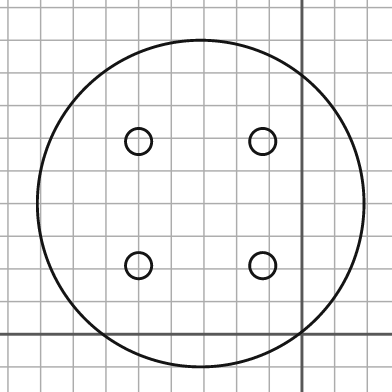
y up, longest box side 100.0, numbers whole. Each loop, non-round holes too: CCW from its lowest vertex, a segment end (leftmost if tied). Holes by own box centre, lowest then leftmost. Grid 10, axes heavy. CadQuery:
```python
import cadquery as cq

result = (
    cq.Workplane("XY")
    .moveTo(-31.0, 40.0)
    .circle(50.0)
    .moveTo(-50.0, 21.0)
    .circle(4.0)
    .moveTo(-12.0, 21.0)
    .circle(4.0)
    .moveTo(-50.0, 59.0)
    .circle(4.0)
    .moveTo(-12.0, 59.0)
    .circle(4.0)
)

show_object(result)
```